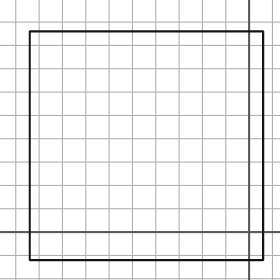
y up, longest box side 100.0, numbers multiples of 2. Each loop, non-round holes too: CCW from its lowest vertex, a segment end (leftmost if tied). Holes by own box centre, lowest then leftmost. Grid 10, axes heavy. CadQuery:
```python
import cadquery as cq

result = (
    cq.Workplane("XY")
    .moveTo(-94.0, -12.0)
    .lineTo(6.0, -12.0)
    .lineTo(6.0, 86.0)
    .lineTo(-94.0, 86.0)
    .close()
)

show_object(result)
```